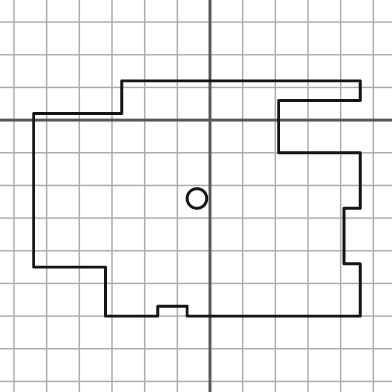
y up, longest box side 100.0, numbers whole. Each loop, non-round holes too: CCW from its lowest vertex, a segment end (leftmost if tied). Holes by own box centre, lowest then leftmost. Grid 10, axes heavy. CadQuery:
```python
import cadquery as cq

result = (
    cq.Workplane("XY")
    .moveTo(-32.0, -60.0)
    .lineTo(-16.0, -60.0)
    .lineTo(-16.0, -57.0)
    .lineTo(-7.0, -57.0)
    .lineTo(-7.0, -60.0)
    .lineTo(46.0, -60.0)
    .lineTo(46.0, -44.0)
    .lineTo(41.0, -44.0)
    .lineTo(41.0, -27.0)
    .lineTo(46.0, -27.0)
    .lineTo(46.0, -10.0)
    .lineTo(21.0, -10.0)
    .lineTo(21.0, 6.0)
    .lineTo(46.0, 6.0)
    .lineTo(46.0, 12.0)
    .lineTo(-27.0, 12.0)
    .lineTo(-27.0, 2.0)
    .lineTo(-54.0, 2.0)
    .lineTo(-54.0, -45.0)
    .lineTo(-32.0, -45.0)
    .close()
    .moveTo(-4.0, -24.0)
    .circle(3.0)
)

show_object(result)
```